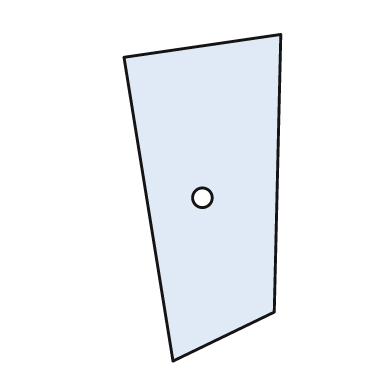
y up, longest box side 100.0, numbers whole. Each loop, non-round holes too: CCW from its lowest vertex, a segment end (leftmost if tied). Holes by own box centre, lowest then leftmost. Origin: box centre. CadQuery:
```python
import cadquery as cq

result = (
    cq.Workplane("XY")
    .moveTo(-9.0, -50.0)
    .lineTo(22.0, -35.0)
    .lineTo(24.0, 50.0)
    .lineTo(-24.0, 43.0)
    .close()
    .moveTo(0.0, 0.0)
    .circle(3.0)
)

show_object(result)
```